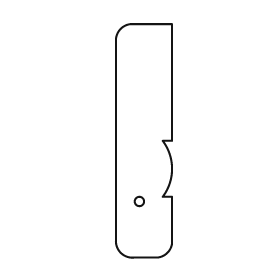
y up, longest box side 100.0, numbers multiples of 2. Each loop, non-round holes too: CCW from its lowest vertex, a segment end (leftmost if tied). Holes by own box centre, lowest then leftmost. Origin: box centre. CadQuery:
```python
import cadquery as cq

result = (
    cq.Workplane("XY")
    .moveTo(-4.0, -50.0)
    .lineTo(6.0, -50.0)
    .threePointArc((10.0, -48.0), (12.0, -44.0))
    .lineTo(12.0, -24.0)
    .lineTo(8.0, -24.0)
    .threePointArc((12.0, -12.0), (8.0, 0.0))
    .lineTo(12.0, 0.0)
    .lineTo(12.0, 50.0)
    .lineTo(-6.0, 50.0)
    .threePointArc((-10.0, 48.0), (-12.0, 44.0))
    .lineTo(-12.0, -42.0)
    .threePointArc((-10.0, -48.0), (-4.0, -50.0))
    .close()
    .moveTo(-2.0, -26.0)
    .circle(2.0)
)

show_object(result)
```